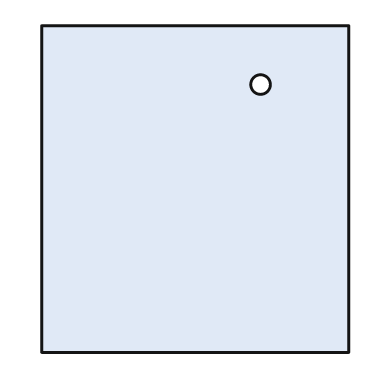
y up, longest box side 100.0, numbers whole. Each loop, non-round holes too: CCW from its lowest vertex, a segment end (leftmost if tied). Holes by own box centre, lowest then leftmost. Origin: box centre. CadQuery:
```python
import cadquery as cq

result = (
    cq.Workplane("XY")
    .moveTo(-47.0, -50.0)
    .lineTo(47.0, -50.0)
    .lineTo(47.0, 50.0)
    .lineTo(-47.0, 50.0)
    .close()
    .moveTo(20.0, 32.0)
    .circle(3.0)
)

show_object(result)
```